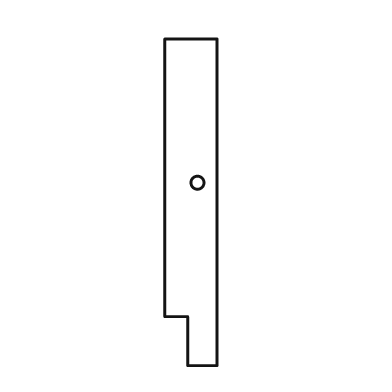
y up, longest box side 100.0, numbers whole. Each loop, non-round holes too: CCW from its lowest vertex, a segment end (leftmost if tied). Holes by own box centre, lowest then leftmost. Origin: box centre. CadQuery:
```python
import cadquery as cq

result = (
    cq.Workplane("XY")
    .moveTo(-1.0, -50.0)
    .lineTo(8.0, -50.0)
    .lineTo(8.0, 50.0)
    .lineTo(-8.0, 50.0)
    .lineTo(-8.0, -35.0)
    .lineTo(-1.0, -35.0)
    .close()
    .moveTo(2.0, 6.0)
    .circle(2.0)
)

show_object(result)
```